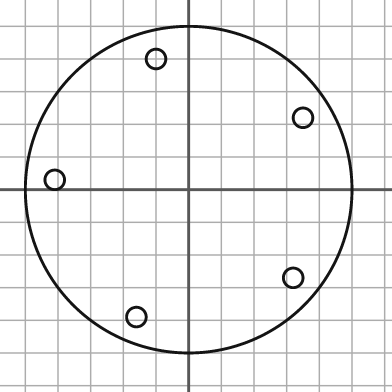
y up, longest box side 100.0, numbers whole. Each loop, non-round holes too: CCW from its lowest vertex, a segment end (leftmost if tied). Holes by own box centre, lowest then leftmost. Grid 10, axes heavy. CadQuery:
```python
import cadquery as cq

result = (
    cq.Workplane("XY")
    .moveTo(0.0, 0.0)
    .circle(50.0)
    .moveTo(-16.0, -39.0)
    .circle(3.0)
    .moveTo(32.0, -27.0)
    .circle(3.0)
    .moveTo(-41.0, 3.0)
    .circle(3.0)
    .moveTo(35.0, 22.0)
    .circle(3.0)
    .moveTo(-10.0, 40.0)
    .circle(3.0)
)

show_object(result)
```